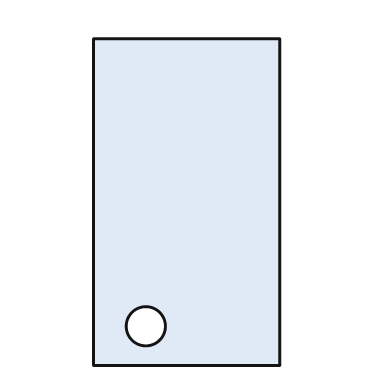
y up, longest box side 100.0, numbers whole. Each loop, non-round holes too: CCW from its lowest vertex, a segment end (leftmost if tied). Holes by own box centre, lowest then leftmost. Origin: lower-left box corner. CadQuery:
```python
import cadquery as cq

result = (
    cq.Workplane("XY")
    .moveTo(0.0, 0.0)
    .lineTo(57.0, 0.0)
    .lineTo(57.0, 100.0)
    .lineTo(0.0, 100.0)
    .close()
    .moveTo(16.0, 12.0)
    .circle(6.0)
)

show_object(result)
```